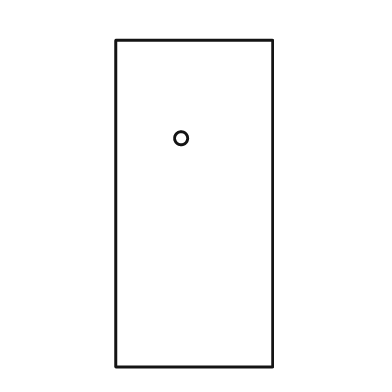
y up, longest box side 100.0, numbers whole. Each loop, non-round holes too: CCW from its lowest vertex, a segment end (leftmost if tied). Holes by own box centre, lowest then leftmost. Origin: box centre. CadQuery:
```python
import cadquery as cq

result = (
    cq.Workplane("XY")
    .moveTo(-24.0, -50.0)
    .lineTo(24.0, -50.0)
    .lineTo(24.0, 50.0)
    .lineTo(-24.0, 50.0)
    .close()
    .moveTo(-4.0, 20.0)
    .circle(2.0)
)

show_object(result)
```